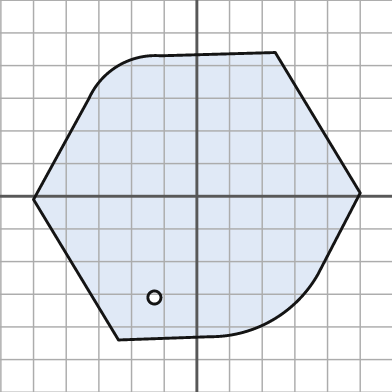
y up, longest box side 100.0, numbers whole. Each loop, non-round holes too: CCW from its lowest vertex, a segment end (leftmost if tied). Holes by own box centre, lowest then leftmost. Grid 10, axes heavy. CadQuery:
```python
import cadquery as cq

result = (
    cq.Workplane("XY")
    .moveTo(-24.0, -44.0)
    .lineTo(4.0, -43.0)
    .threePointArc((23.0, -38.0), (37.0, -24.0))
    .lineTo(50.0, 1.0)
    .lineTo(24.0, 44.0)
    .lineTo(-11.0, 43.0)
    .threePointArc((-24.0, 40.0), (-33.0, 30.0))
    .lineTo(-50.0, -1.0)
    .close()
    .moveTo(-13.0, -31.0)
    .circle(2.0)
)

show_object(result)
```